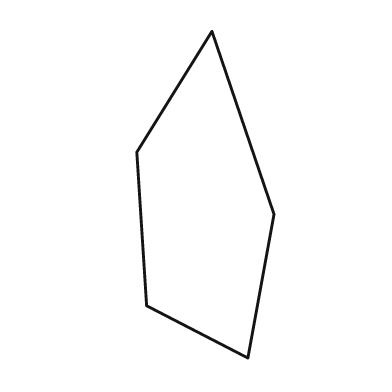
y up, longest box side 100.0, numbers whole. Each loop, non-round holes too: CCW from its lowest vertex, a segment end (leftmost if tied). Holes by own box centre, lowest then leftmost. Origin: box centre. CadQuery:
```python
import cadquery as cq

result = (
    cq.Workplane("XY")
    .moveTo(13.0, -50.0)
    .lineTo(21.0, -6.0)
    .lineTo(2.0, 50.0)
    .lineTo(-21.0, 13.0)
    .lineTo(-18.0, -34.0)
    .close()
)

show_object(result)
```